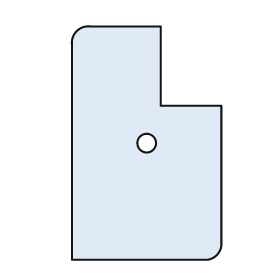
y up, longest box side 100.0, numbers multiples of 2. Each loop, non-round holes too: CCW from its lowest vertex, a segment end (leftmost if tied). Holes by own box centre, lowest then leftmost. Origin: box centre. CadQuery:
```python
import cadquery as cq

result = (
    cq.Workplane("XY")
    .moveTo(-32.0, -50.0)
    .lineTo(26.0, -50.0)
    .threePointArc((30.0, -48.0), (32.0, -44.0))
    .lineTo(32.0, 16.0)
    .lineTo(6.0, 16.0)
    .lineTo(6.0, 50.0)
    .lineTo(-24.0, 50.0)
    .threePointArc((-30.0, 48.0), (-32.0, 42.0))
    .close()
    .moveTo(0.0, 0.0)
    .circle(4.0)
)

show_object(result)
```